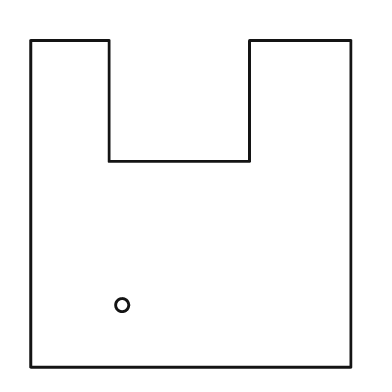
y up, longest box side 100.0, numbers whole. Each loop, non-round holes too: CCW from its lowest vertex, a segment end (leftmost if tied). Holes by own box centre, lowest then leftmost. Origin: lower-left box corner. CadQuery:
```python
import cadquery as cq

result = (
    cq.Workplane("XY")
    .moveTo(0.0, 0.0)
    .lineTo(98.0, 0.0)
    .lineTo(98.0, 100.0)
    .lineTo(67.0, 100.0)
    .lineTo(67.0, 63.0)
    .lineTo(24.0, 63.0)
    .lineTo(24.0, 100.0)
    .lineTo(0.0, 100.0)
    .close()
    .moveTo(28.0, 19.0)
    .circle(2.0)
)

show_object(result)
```